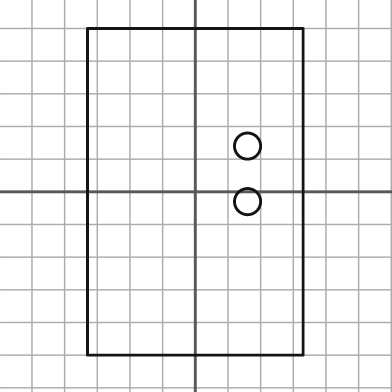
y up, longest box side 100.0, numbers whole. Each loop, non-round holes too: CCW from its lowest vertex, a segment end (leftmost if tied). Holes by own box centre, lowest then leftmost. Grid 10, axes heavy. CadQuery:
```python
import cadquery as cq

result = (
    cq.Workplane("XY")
    .moveTo(-33.0, -50.0)
    .lineTo(33.0, -50.0)
    .lineTo(33.0, 50.0)
    .lineTo(-33.0, 50.0)
    .close()
    .moveTo(16.0, -3.0)
    .circle(4.0)
    .moveTo(16.0, 14.0)
    .circle(4.0)
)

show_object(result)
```